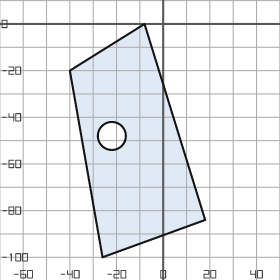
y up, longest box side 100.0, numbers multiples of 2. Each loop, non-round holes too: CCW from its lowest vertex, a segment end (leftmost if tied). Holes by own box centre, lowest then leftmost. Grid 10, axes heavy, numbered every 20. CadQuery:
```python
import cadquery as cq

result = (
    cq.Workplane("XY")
    .moveTo(-26.0, -100.0)
    .lineTo(18.0, -84.0)
    .lineTo(-8.0, 0.0)
    .lineTo(-40.0, -20.0)
    .close()
    .moveTo(-22.0, -48.0)
    .circle(6.0)
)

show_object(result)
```